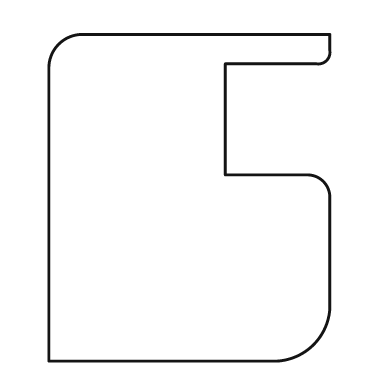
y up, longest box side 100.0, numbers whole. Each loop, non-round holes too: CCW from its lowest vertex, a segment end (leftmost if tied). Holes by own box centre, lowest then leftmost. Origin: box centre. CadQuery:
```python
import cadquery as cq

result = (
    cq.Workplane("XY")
    .moveTo(-43.0, -50.0)
    .lineTo(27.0, -50.0)
    .threePointArc((38.0, -45.0), (43.0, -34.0))
    .lineTo(43.0, 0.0)
    .threePointArc((41.0, 5.0), (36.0, 7.0))
    .lineTo(11.0, 7.0)
    .lineTo(11.0, 41.0)
    .lineTo(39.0, 41.0)
    .threePointArc((42.0, 42.0), (43.0, 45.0))
    .lineTo(43.0, 50.0)
    .lineTo(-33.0, 50.0)
    .threePointArc((-40.0, 47.0), (-43.0, 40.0))
    .close()
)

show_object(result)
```